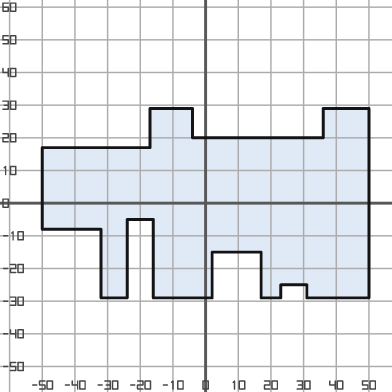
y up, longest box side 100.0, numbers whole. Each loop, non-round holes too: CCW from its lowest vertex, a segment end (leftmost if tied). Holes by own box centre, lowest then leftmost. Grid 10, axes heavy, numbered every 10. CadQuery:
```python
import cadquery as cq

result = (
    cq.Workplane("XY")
    .moveTo(-32.0, -29.0)
    .lineTo(-24.0, -29.0)
    .lineTo(-24.0, -5.0)
    .lineTo(-16.0, -5.0)
    .lineTo(-16.0, -29.0)
    .lineTo(2.0, -29.0)
    .lineTo(2.0, -15.0)
    .lineTo(17.0, -15.0)
    .lineTo(17.0, -29.0)
    .lineTo(23.0, -29.0)
    .lineTo(23.0, -25.0)
    .lineTo(31.0, -25.0)
    .lineTo(31.0, -29.0)
    .lineTo(50.0, -29.0)
    .lineTo(50.0, 29.0)
    .lineTo(36.0, 29.0)
    .lineTo(36.0, 20.0)
    .lineTo(-4.0, 20.0)
    .lineTo(-4.0, 29.0)
    .lineTo(-17.0, 29.0)
    .lineTo(-17.0, 17.0)
    .lineTo(-50.0, 17.0)
    .lineTo(-50.0, -8.0)
    .lineTo(-32.0, -8.0)
    .close()
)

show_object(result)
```